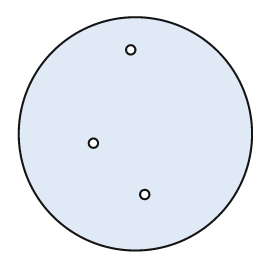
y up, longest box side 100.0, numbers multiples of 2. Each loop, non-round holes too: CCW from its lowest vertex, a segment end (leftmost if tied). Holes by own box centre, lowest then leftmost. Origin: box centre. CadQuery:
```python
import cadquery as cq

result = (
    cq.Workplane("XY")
    .moveTo(0.0, 0.0)
    .circle(50.0)
    .moveTo(4.0, -26.0)
    .circle(2.0)
    .moveTo(-18.0, -4.0)
    .circle(2.0)
    .moveTo(-2.0, 36.0)
    .circle(2.0)
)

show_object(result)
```